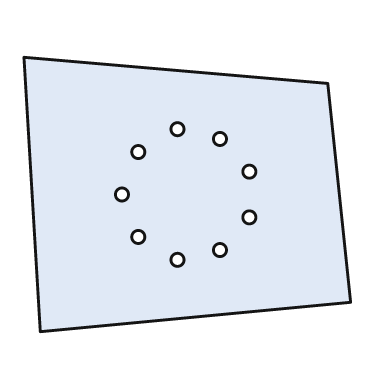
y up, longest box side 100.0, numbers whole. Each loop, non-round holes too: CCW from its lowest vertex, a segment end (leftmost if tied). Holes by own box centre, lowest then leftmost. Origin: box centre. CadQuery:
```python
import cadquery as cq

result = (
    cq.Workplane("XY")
    .moveTo(-45.0, -42.0)
    .lineTo(50.0, -33.0)
    .lineTo(43.0, 34.0)
    .lineTo(-50.0, 42.0)
    .close()
    .moveTo(-3.0, -20.0)
    .circle(2.0)
    .moveTo(10.0, -17.0)
    .circle(2.0)
    .moveTo(-15.0, -13.0)
    .circle(2.0)
    .moveTo(19.0, -7.0)
    .circle(2.0)
    .moveTo(-20.0, 0.0)
    .circle(2.0)
    .moveTo(19.0, 7.0)
    .circle(2.0)
    .moveTo(-15.0, 13.0)
    .circle(2.0)
    .moveTo(10.0, 17.0)
    .circle(2.0)
    .moveTo(-3.0, 20.0)
    .circle(2.0)
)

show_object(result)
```